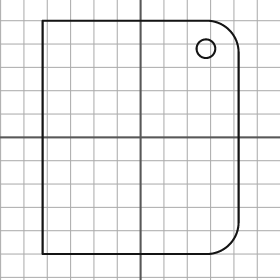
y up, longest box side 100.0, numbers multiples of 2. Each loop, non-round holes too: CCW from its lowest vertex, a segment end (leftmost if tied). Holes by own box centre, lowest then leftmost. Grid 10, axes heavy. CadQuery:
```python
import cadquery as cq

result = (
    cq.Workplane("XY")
    .moveTo(-42.0, -50.0)
    .lineTo(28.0, -50.0)
    .threePointArc((38.0, -46.0), (42.0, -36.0))
    .lineTo(42.0, 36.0)
    .threePointArc((38.0, 46.0), (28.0, 50.0))
    .lineTo(-42.0, 50.0)
    .close()
    .moveTo(28.0, 38.0)
    .circle(4.0)
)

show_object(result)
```